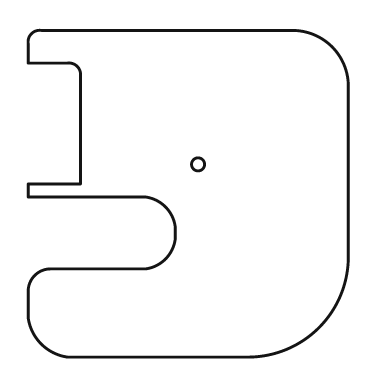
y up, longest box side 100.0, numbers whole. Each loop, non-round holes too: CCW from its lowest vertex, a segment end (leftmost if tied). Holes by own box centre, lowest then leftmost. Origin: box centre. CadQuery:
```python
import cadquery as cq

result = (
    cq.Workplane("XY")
    .moveTo(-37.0, -50.0)
    .lineTo(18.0, -50.0)
    .threePointArc((40.0, -41.0), (49.0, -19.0))
    .lineTo(49.0, 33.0)
    .threePointArc((44.0, 45.0), (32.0, 50.0))
    .lineTo(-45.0, 50.0)
    .threePointArc((-48.0, 49.0), (-49.0, 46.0))
    .lineTo(-49.0, 40.0)
    .lineTo(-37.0, 40.0)
    .threePointArc((-34.0, 39.0), (-33.0, 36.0))
    .lineTo(-33.0, 3.0)
    .lineTo(-49.0, 3.0)
    .lineTo(-49.0, -1.0)
    .lineTo(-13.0, -1.0)
    .threePointArc((-7.0, -4.0), (-4.0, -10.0))
    .lineTo(-4.0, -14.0)
    .threePointArc((-7.0, -20.0), (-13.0, -23.0))
    .lineTo(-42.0, -23.0)
    .threePointArc((-47.0, -25.0), (-49.0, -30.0))
    .lineTo(-49.0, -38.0)
    .threePointArc((-45.0, -46.0), (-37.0, -50.0))
    .close()
    .moveTo(3.0, 9.0)
    .circle(2.0)
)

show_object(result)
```